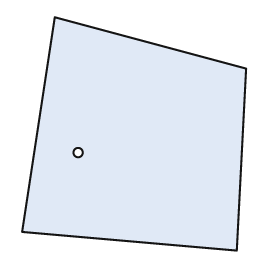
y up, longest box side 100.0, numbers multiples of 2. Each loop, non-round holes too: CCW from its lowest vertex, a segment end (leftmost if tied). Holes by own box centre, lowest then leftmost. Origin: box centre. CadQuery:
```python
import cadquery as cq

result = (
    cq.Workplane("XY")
    .moveTo(44.0, -50.0)
    .lineTo(48.0, 28.0)
    .lineTo(-34.0, 50.0)
    .lineTo(-48.0, -42.0)
    .close()
    .moveTo(-24.0, -8.0)
    .circle(2.0)
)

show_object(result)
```